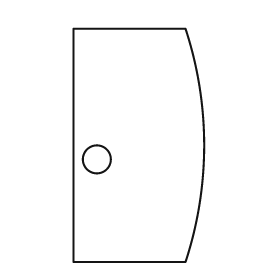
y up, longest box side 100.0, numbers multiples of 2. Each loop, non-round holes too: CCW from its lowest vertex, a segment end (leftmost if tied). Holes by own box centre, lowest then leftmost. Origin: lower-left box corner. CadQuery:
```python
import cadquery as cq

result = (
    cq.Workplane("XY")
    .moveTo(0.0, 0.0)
    .lineTo(48.0, 0.0)
    .threePointArc((56.0, 50.0), (48.0, 100.0))
    .lineTo(0.0, 100.0)
    .close()
    .moveTo(10.0, 44.0)
    .circle(6.0)
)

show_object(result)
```